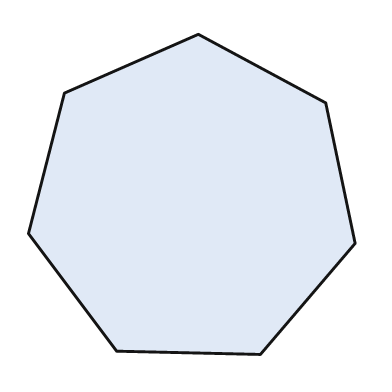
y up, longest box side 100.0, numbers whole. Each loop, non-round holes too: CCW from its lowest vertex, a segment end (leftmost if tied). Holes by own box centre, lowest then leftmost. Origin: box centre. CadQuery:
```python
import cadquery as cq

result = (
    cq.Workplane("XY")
    .moveTo(21.0, -49.0)
    .lineTo(50.0, -15.0)
    .lineTo(41.0, 28.0)
    .lineTo(2.0, 49.0)
    .lineTo(-39.0, 31.0)
    .lineTo(-50.0, -12.0)
    .lineTo(-23.0, -48.0)
    .close()
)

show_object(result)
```